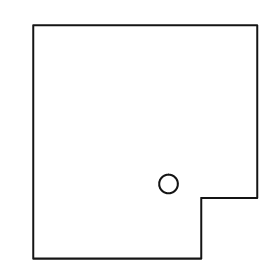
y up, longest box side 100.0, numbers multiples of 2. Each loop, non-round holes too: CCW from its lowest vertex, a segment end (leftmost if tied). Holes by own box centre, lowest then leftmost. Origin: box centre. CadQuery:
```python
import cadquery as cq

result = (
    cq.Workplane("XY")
    .moveTo(-48.0, -50.0)
    .lineTo(24.0, -50.0)
    .lineTo(24.0, -24.0)
    .lineTo(48.0, -24.0)
    .lineTo(48.0, 50.0)
    .lineTo(-48.0, 50.0)
    .close()
    .moveTo(10.0, -18.0)
    .circle(4.0)
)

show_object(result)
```